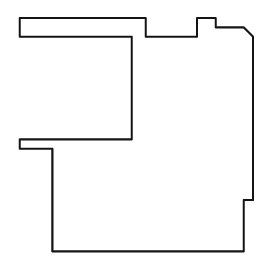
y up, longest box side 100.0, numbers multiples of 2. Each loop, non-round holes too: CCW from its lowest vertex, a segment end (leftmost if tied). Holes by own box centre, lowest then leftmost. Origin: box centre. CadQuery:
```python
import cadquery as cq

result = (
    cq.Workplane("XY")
    .moveTo(-36.0, -50.0)
    .lineTo(46.0, -50.0)
    .lineTo(46.0, -28.0)
    .lineTo(50.0, -28.0)
    .lineTo(50.0, 42.0)
    .lineTo(46.0, 46.0)
    .lineTo(34.0, 46.0)
    .lineTo(34.0, 50.0)
    .lineTo(26.0, 50.0)
    .lineTo(26.0, 42.0)
    .lineTo(4.0, 42.0)
    .lineTo(4.0, 50.0)
    .lineTo(-50.0, 50.0)
    .lineTo(-50.0, 42.0)
    .lineTo(-2.0, 42.0)
    .lineTo(-2.0, -2.0)
    .lineTo(-50.0, -2.0)
    .lineTo(-50.0, -6.0)
    .lineTo(-36.0, -6.0)
    .close()
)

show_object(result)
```